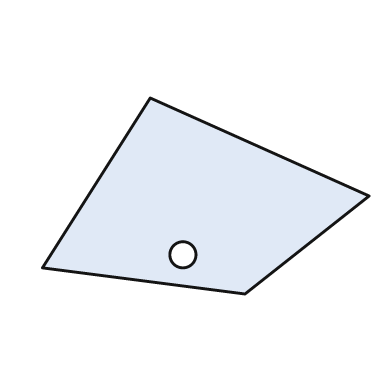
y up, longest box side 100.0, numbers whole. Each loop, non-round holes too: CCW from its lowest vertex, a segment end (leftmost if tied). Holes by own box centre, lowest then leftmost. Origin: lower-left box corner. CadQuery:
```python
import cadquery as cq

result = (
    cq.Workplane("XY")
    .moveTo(62.0, 0.0)
    .lineTo(100.0, 30.0)
    .lineTo(33.0, 60.0)
    .lineTo(0.0, 8.0)
    .close()
    .moveTo(43.0, 12.0)
    .circle(4.0)
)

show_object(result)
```